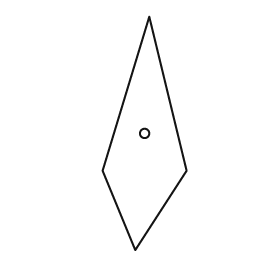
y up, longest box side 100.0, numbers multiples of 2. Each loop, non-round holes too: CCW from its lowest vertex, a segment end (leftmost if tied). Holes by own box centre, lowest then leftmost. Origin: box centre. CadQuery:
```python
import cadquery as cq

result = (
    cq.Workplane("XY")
    .moveTo(-4.0, -50.0)
    .lineTo(18.0, -16.0)
    .lineTo(2.0, 50.0)
    .lineTo(-18.0, -16.0)
    .close()
    .moveTo(0.0, 0.0)
    .circle(2.0)
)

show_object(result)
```